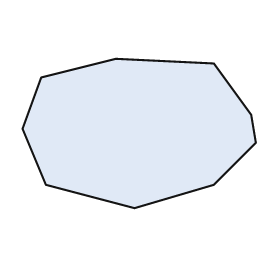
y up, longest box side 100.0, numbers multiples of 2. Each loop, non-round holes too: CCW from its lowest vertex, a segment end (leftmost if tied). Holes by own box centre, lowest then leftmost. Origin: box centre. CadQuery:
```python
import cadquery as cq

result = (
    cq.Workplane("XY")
    .moveTo(-2.0, -32.0)
    .lineTo(32.0, -22.0)
    .lineTo(50.0, -4.0)
    .lineTo(48.0, 8.0)
    .lineTo(32.0, 30.0)
    .lineTo(-10.0, 32.0)
    .lineTo(-42.0, 24.0)
    .lineTo(-50.0, 2.0)
    .lineTo(-40.0, -22.0)
    .close()
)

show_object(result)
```